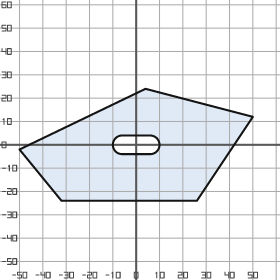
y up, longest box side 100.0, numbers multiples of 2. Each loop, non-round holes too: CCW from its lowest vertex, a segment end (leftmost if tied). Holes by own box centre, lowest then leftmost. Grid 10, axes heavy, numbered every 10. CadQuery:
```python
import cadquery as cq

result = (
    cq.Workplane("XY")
    .moveTo(-32.0, -24.0)
    .lineTo(26.0, -24.0)
    .lineTo(50.0, 12.0)
    .lineTo(4.0, 24.0)
    .lineTo(-50.0, -2.0)
    .close()
    .moveTo(-6.0, -4.0)
    .lineTo(6.0, -4.0)
    .threePointArc((10.0, 0.0), (6.0, 4.0))
    .lineTo(-6.0, 4.0)
    .threePointArc((-10.0, 0.0), (-6.0, -4.0))
    .close()
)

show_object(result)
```